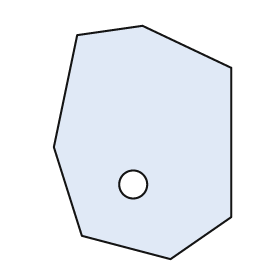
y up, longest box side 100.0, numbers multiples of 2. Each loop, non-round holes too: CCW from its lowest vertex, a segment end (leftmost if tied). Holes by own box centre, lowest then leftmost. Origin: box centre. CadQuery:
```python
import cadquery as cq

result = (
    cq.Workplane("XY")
    .moveTo(12.0, -50.0)
    .lineTo(38.0, -32.0)
    .lineTo(38.0, 32.0)
    .lineTo(0.0, 50.0)
    .lineTo(-28.0, 46.0)
    .lineTo(-38.0, -2.0)
    .lineTo(-26.0, -40.0)
    .close()
    .moveTo(-4.0, -18.0)
    .circle(6.0)
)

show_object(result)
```